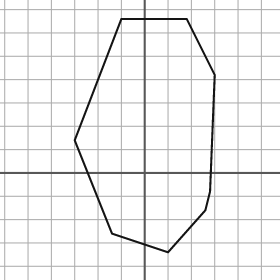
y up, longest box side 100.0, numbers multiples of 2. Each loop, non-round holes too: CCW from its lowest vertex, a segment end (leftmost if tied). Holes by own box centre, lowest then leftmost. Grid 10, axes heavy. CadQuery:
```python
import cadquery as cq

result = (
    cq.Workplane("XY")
    .moveTo(10.0, -34.0)
    .lineTo(26.0, -16.0)
    .lineTo(28.0, -8.0)
    .lineTo(30.0, 42.0)
    .lineTo(18.0, 66.0)
    .lineTo(-10.0, 66.0)
    .lineTo(-30.0, 14.0)
    .lineTo(-14.0, -26.0)
    .close()
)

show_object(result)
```